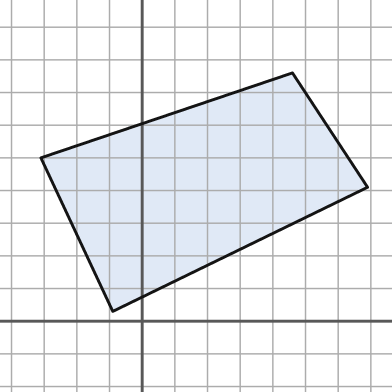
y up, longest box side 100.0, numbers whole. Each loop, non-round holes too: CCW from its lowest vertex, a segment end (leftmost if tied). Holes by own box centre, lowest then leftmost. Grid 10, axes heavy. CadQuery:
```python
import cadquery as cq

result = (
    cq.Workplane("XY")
    .moveTo(-9.0, 3.0)
    .lineTo(69.0, 41.0)
    .lineTo(46.0, 76.0)
    .lineTo(-31.0, 50.0)
    .close()
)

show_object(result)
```